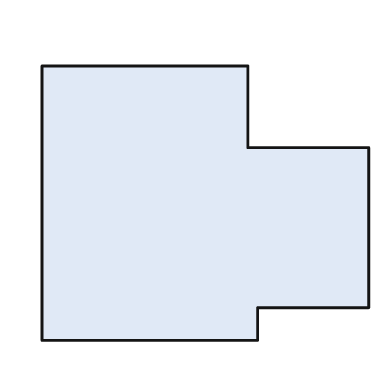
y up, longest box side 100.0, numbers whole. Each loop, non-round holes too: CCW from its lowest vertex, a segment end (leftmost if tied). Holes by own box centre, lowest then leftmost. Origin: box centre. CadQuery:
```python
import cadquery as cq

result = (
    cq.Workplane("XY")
    .moveTo(-50.0, -42.0)
    .lineTo(16.0, -42.0)
    .lineTo(16.0, -32.0)
    .lineTo(50.0, -32.0)
    .lineTo(50.0, 17.0)
    .lineTo(13.0, 17.0)
    .lineTo(13.0, 42.0)
    .lineTo(-50.0, 42.0)
    .close()
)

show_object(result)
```